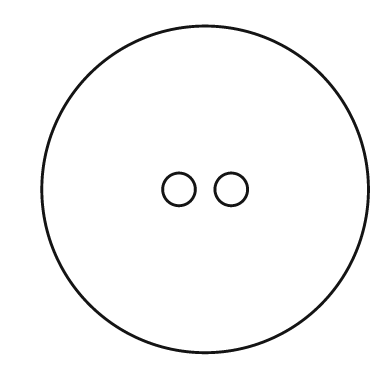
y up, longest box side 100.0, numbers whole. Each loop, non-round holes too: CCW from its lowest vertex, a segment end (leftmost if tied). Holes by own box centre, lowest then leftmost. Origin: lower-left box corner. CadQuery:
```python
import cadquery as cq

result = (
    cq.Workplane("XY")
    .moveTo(50.0, 50.0)
    .circle(50.0)
    .moveTo(42.0, 50.0)
    .circle(5.0)
    .moveTo(58.0, 50.0)
    .circle(5.0)
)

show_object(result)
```